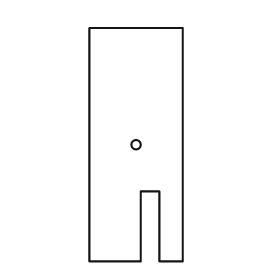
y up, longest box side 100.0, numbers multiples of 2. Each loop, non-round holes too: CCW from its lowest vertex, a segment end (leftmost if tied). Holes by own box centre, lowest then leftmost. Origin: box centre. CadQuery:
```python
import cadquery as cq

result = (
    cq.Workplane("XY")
    .moveTo(-20.0, -50.0)
    .lineTo(2.0, -50.0)
    .lineTo(2.0, -20.0)
    .lineTo(10.0, -20.0)
    .lineTo(10.0, -50.0)
    .lineTo(20.0, -50.0)
    .lineTo(20.0, 50.0)
    .lineTo(-20.0, 50.0)
    .close()
    .moveTo(0.0, 0.0)
    .circle(2.0)
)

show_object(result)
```